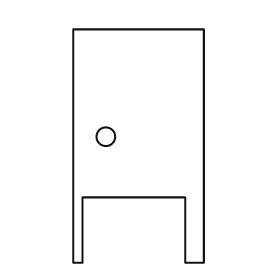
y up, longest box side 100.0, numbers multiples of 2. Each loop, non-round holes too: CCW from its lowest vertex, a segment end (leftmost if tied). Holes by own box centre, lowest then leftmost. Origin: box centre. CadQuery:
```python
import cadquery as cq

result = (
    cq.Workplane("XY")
    .moveTo(-28.0, -50.0)
    .lineTo(-24.0, -50.0)
    .lineTo(-24.0, -22.0)
    .lineTo(20.0, -22.0)
    .lineTo(20.0, -50.0)
    .lineTo(28.0, -50.0)
    .lineTo(28.0, 50.0)
    .lineTo(-28.0, 50.0)
    .close()
    .moveTo(-14.0, 4.0)
    .circle(4.0)
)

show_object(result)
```